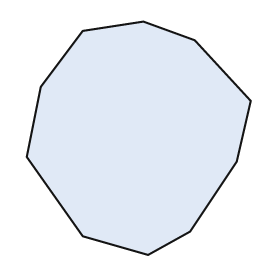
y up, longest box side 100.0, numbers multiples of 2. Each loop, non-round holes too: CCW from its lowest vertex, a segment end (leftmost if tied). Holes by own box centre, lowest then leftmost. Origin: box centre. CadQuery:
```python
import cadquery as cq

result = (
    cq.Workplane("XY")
    .moveTo(4.0, -50.0)
    .lineTo(22.0, -40.0)
    .lineTo(42.0, -10.0)
    .lineTo(48.0, 16.0)
    .lineTo(24.0, 42.0)
    .lineTo(2.0, 50.0)
    .lineTo(-24.0, 46.0)
    .lineTo(-42.0, 22.0)
    .lineTo(-48.0, -8.0)
    .lineTo(-24.0, -42.0)
    .close()
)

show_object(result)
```